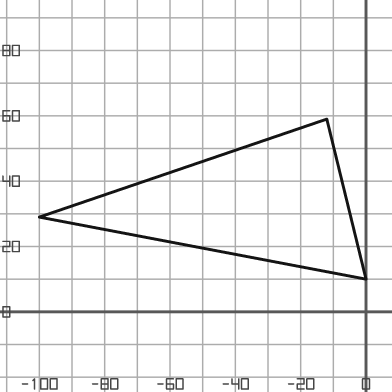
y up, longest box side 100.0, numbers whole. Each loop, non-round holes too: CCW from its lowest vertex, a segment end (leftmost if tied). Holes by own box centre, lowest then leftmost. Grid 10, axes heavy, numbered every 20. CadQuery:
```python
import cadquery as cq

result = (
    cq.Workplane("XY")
    .moveTo(0.0, 10.0)
    .lineTo(-12.0, 59.0)
    .lineTo(-100.0, 29.0)
    .close()
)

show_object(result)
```